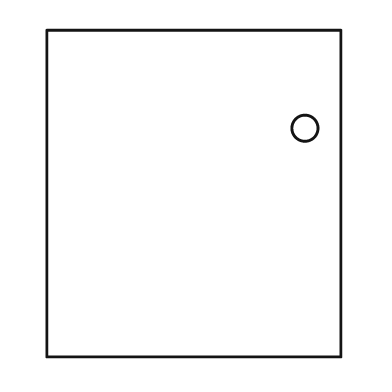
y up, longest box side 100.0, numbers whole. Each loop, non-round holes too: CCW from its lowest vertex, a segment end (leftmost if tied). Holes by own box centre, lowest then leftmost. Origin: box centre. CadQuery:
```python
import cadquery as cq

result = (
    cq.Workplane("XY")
    .moveTo(-45.0, -50.0)
    .lineTo(45.0, -50.0)
    .lineTo(45.0, 50.0)
    .lineTo(-45.0, 50.0)
    .close()
    .moveTo(34.0, 20.0)
    .circle(4.0)
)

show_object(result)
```